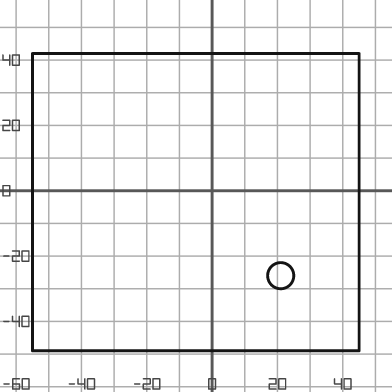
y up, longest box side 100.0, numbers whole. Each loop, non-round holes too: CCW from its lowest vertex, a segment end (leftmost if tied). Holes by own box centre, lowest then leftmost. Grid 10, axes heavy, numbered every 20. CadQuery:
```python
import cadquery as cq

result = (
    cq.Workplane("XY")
    .moveTo(-55.0, -49.0)
    .lineTo(45.0, -49.0)
    .lineTo(45.0, 42.0)
    .lineTo(-55.0, 42.0)
    .close()
    .moveTo(21.0, -26.0)
    .circle(4.0)
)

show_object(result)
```